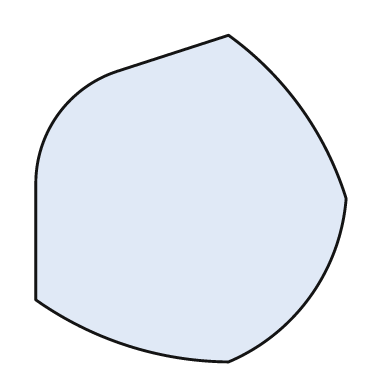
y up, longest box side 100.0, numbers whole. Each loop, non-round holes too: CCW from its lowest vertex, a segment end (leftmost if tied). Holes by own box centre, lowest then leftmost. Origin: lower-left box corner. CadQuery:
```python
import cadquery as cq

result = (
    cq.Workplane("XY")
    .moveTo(59.0, 0.0)
    .threePointArc((84.0, 20.0), (95.0, 50.0))
    .threePointArc((81.0, 78.0), (59.0, 100.0))
    .lineTo(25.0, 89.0)
    .threePointArc((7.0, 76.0), (0.0, 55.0))
    .lineTo(0.0, 19.0)
    .threePointArc((28.0, 5.0), (59.0, 0.0))
    .close()
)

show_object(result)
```